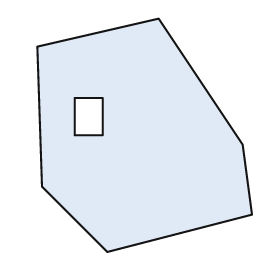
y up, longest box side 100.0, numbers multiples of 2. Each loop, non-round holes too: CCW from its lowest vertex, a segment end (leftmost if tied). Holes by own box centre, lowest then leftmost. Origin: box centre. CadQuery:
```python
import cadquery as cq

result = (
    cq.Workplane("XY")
    .moveTo(-16.0, -50.0)
    .lineTo(46.0, -34.0)
    .lineTo(42.0, -4.0)
    .lineTo(6.0, 50.0)
    .lineTo(-46.0, 38.0)
    .lineTo(-44.0, -22.0)
    .close()
    .moveTo(-30.0, 0.0)
    .lineTo(-18.0, 0.0)
    .lineTo(-18.0, 16.0)
    .lineTo(-30.0, 16.0)
    .close()
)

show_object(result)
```